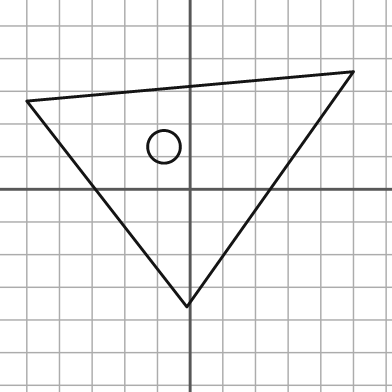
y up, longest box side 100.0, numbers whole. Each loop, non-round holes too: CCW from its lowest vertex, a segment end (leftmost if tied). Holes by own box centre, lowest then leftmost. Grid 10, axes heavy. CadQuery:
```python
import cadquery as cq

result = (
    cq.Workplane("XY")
    .moveTo(-1.0, -36.0)
    .lineTo(50.0, 36.0)
    .lineTo(-50.0, 27.0)
    .close()
    .moveTo(-8.0, 13.0)
    .circle(5.0)
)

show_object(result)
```